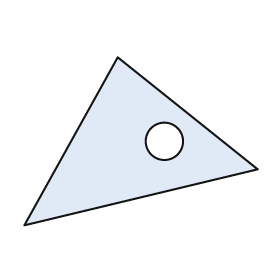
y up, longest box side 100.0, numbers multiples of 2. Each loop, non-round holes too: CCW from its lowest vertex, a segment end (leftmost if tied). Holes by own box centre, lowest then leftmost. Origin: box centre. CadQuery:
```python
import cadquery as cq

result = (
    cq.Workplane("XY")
    .moveTo(-50.0, -36.0)
    .lineTo(50.0, -12.0)
    .lineTo(-10.0, 36.0)
    .close()
    .moveTo(10.0, 0.0)
    .circle(8.0)
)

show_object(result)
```